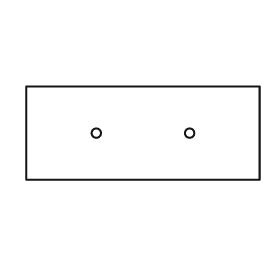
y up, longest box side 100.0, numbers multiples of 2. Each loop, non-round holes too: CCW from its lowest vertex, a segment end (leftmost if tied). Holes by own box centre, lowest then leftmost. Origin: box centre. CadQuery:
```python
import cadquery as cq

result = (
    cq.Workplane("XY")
    .moveTo(-50.0, -20.0)
    .lineTo(50.0, -20.0)
    .lineTo(50.0, 20.0)
    .lineTo(-50.0, 20.0)
    .close()
    .moveTo(-20.0, 0.0)
    .circle(2.0)
    .moveTo(20.0, 0.0)
    .circle(2.0)
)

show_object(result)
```